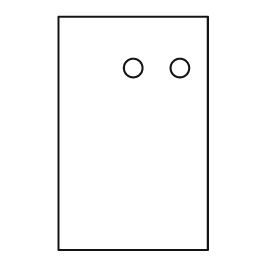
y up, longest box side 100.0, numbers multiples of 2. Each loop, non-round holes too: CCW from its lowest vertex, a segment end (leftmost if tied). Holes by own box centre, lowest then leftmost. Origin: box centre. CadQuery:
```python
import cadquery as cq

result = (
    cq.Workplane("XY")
    .moveTo(-32.0, -50.0)
    .lineTo(32.0, -50.0)
    .lineTo(32.0, 50.0)
    .lineTo(-32.0, 50.0)
    .close()
    .moveTo(0.0, 28.0)
    .circle(4.0)
    .moveTo(20.0, 28.0)
    .circle(4.0)
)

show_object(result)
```